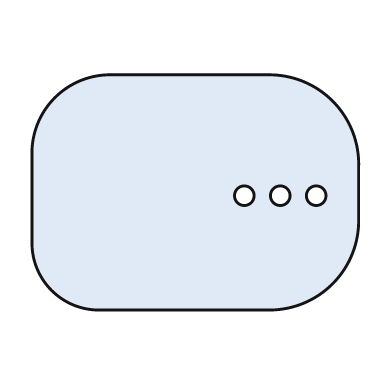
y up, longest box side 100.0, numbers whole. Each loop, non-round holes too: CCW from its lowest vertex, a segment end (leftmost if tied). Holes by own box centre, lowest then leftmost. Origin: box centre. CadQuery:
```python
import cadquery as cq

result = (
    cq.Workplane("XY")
    .moveTo(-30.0, -36.0)
    .lineTo(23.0, -36.0)
    .threePointArc((42.0, -28.0), (50.0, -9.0))
    .lineTo(50.0, 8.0)
    .threePointArc((42.0, 28.0), (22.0, 36.0))
    .lineTo(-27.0, 36.0)
    .threePointArc((-43.0, 29.0), (-50.0, 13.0))
    .lineTo(-50.0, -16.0)
    .threePointArc((-44.0, -30.0), (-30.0, -36.0))
    .close()
    .moveTo(15.0, -1.0)
    .circle(3.0)
    .moveTo(26.0, -1.0)
    .circle(3.0)
    .moveTo(37.0, -1.0)
    .circle(3.0)
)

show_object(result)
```